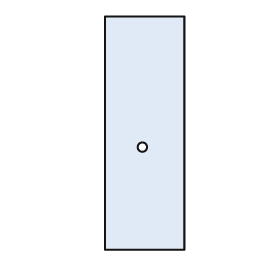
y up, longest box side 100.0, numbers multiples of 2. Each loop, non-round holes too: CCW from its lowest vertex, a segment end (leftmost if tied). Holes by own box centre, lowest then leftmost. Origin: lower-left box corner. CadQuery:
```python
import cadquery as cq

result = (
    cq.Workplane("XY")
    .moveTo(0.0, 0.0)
    .lineTo(34.0, 0.0)
    .lineTo(34.0, 100.0)
    .lineTo(0.0, 100.0)
    .close()
    .moveTo(16.0, 44.0)
    .circle(2.0)
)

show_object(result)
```